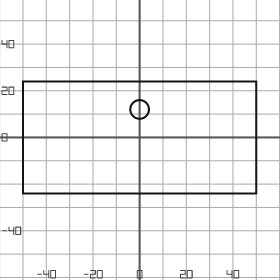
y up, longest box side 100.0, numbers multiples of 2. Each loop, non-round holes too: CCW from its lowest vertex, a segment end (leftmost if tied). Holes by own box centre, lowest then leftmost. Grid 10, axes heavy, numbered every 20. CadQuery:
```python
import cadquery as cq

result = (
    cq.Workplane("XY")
    .moveTo(-50.0, -24.0)
    .lineTo(50.0, -24.0)
    .lineTo(50.0, 24.0)
    .lineTo(-50.0, 24.0)
    .close()
    .moveTo(0.0, 12.0)
    .circle(4.0)
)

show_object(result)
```